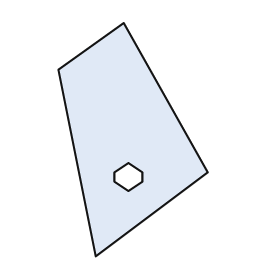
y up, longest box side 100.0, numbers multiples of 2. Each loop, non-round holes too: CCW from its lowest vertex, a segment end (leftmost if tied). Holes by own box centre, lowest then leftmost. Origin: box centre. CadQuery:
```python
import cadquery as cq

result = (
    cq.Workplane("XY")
    .moveTo(-16.0, -50.0)
    .lineTo(32.0, -14.0)
    .lineTo(-4.0, 50.0)
    .lineTo(-32.0, 30.0)
    .close()
    .moveTo(-2.0, -22.0)
    .lineTo(4.0, -18.0)
    .lineTo(4.0, -14.0)
    .lineTo(-2.0, -10.0)
    .lineTo(-8.0, -14.0)
    .lineTo(-8.0, -18.0)
    .close()
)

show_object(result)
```